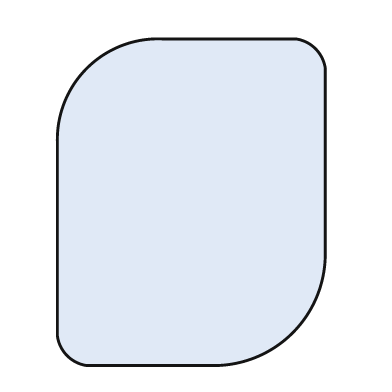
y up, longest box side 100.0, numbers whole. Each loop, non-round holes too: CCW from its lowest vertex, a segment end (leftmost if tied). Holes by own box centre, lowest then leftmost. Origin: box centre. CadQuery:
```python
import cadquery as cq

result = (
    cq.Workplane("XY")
    .moveTo(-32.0, -50.0)
    .lineTo(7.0, -50.0)
    .threePointArc((31.0, -40.0), (41.0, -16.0))
    .lineTo(41.0, 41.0)
    .threePointArc((38.0, 47.0), (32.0, 50.0))
    .lineTo(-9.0, 50.0)
    .threePointArc((-32.0, 41.0), (-41.0, 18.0))
    .lineTo(-41.0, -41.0)
    .threePointArc((-38.0, -47.0), (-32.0, -50.0))
    .close()
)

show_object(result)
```